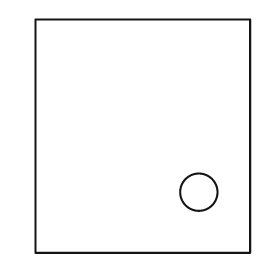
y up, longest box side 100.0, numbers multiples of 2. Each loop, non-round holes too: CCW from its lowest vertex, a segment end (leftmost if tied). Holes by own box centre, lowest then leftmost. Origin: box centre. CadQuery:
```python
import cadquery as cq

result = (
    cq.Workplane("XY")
    .moveTo(-46.0, -50.0)
    .lineTo(46.0, -50.0)
    .lineTo(46.0, 50.0)
    .lineTo(-46.0, 50.0)
    .close()
    .moveTo(24.0, -24.0)
    .circle(8.0)
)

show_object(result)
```